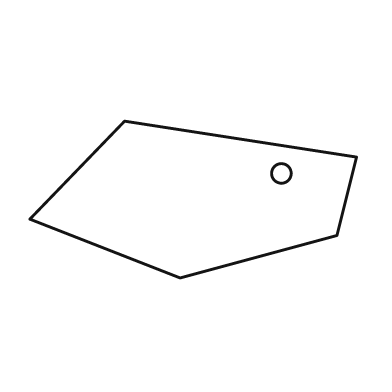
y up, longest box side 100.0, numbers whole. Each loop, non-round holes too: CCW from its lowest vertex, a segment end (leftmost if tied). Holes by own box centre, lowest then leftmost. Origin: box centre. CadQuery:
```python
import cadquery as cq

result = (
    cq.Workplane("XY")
    .moveTo(-4.0, -24.0)
    .lineTo(44.0, -11.0)
    .lineTo(50.0, 13.0)
    .lineTo(-21.0, 24.0)
    .lineTo(-50.0, -6.0)
    .close()
    .moveTo(27.0, 8.0)
    .circle(3.0)
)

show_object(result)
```